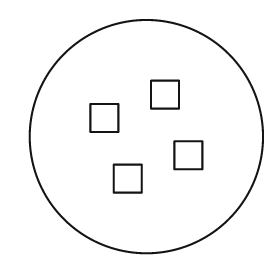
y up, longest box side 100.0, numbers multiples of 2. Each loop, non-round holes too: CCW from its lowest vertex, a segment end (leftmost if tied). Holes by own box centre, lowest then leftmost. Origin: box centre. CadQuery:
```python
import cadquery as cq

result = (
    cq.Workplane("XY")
    .moveTo(0.0, 0.0)
    .circle(50.0)
    .moveTo(-14.0, -24.0)
    .lineTo(-2.0, -24.0)
    .lineTo(-2.0, -12.0)
    .lineTo(-14.0, -12.0)
    .close()
    .moveTo(12.0, -14.0)
    .lineTo(24.0, -14.0)
    .lineTo(24.0, -2.0)
    .lineTo(12.0, -2.0)
    .close()
    .moveTo(-24.0, 2.0)
    .lineTo(-12.0, 2.0)
    .lineTo(-12.0, 14.0)
    .lineTo(-24.0, 14.0)
    .close()
    .moveTo(2.0, 12.0)
    .lineTo(14.0, 12.0)
    .lineTo(14.0, 24.0)
    .lineTo(2.0, 24.0)
    .close()
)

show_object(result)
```